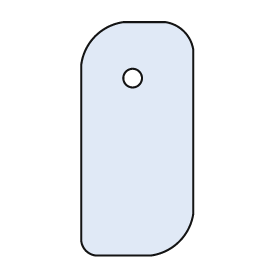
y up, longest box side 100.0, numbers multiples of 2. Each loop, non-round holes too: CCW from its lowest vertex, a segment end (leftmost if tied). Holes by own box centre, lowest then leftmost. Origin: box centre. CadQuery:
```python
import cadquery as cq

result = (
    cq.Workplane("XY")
    .moveTo(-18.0, -50.0)
    .lineTo(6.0, -50.0)
    .threePointArc((18.0, -44.0), (24.0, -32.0))
    .lineTo(24.0, 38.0)
    .threePointArc((20.0, 46.0), (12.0, 50.0))
    .lineTo(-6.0, 50.0)
    .threePointArc((-18.0, 44.0), (-24.0, 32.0))
    .lineTo(-24.0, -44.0)
    .threePointArc((-22.0, -48.0), (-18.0, -50.0))
    .close()
    .moveTo(-2.0, 26.0)
    .circle(4.0)
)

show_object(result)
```